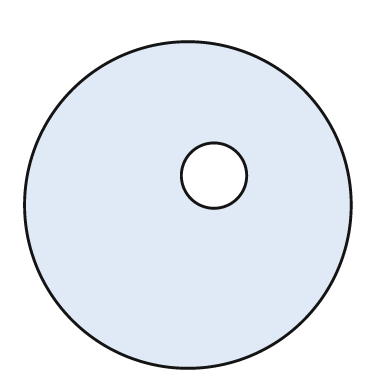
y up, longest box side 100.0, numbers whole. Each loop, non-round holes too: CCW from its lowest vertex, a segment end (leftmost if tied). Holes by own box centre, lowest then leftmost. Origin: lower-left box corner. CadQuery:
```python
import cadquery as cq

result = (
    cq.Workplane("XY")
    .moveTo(50.0, 50.0)
    .circle(50.0)
    .moveTo(58.0, 59.0)
    .circle(10.0)
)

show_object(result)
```